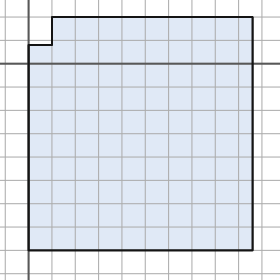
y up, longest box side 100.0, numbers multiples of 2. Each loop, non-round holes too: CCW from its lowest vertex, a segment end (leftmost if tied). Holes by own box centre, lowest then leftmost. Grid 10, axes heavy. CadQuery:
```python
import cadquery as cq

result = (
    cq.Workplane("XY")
    .moveTo(0.0, -80.0)
    .lineTo(96.0, -80.0)
    .lineTo(96.0, 20.0)
    .lineTo(10.0, 20.0)
    .lineTo(10.0, 8.0)
    .lineTo(0.0, 8.0)
    .close()
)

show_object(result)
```